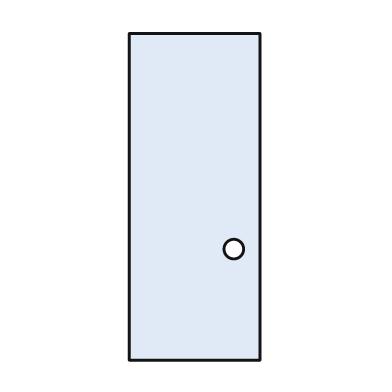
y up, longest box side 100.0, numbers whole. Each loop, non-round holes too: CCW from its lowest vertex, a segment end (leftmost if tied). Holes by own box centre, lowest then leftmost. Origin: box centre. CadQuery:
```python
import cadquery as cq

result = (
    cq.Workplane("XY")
    .moveTo(-20.0, -50.0)
    .lineTo(20.0, -50.0)
    .lineTo(20.0, 50.0)
    .lineTo(-20.0, 50.0)
    .close()
    .moveTo(12.0, -16.0)
    .circle(3.0)
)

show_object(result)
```